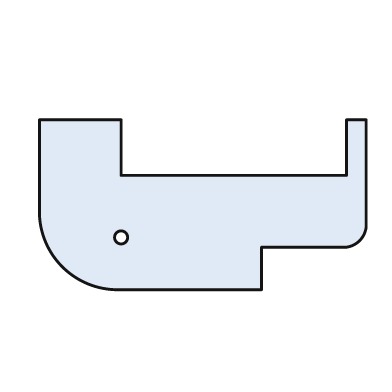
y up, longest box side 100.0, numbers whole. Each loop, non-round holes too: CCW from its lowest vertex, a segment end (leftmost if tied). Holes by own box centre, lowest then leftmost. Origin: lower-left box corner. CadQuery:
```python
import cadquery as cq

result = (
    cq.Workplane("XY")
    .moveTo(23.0, 0.0)
    .lineTo(68.0, 0.0)
    .lineTo(68.0, 13.0)
    .lineTo(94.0, 13.0)
    .threePointArc((98.0, 15.0), (100.0, 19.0))
    .lineTo(100.0, 52.0)
    .lineTo(94.0, 52.0)
    .lineTo(94.0, 35.0)
    .lineTo(25.0, 35.0)
    .lineTo(25.0, 52.0)
    .lineTo(0.0, 52.0)
    .lineTo(0.0, 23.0)
    .threePointArc((7.0, 7.0), (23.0, 0.0))
    .close()
    .moveTo(25.0, 16.0)
    .circle(2.0)
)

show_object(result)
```